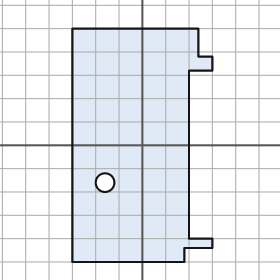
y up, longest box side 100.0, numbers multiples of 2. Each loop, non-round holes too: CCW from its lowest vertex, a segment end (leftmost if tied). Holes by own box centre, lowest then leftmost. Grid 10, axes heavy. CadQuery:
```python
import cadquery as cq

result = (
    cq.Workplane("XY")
    .moveTo(-30.0, -50.0)
    .lineTo(18.0, -50.0)
    .lineTo(18.0, -44.0)
    .lineTo(30.0, -44.0)
    .lineTo(30.0, -40.0)
    .lineTo(20.0, -40.0)
    .lineTo(20.0, 32.0)
    .lineTo(30.0, 32.0)
    .lineTo(30.0, 38.0)
    .lineTo(24.0, 38.0)
    .lineTo(24.0, 50.0)
    .lineTo(-30.0, 50.0)
    .close()
    .moveTo(-16.0, -16.0)
    .circle(4.0)
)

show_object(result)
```